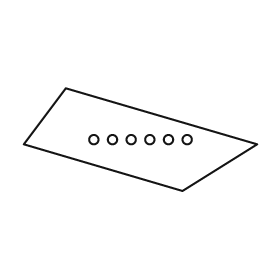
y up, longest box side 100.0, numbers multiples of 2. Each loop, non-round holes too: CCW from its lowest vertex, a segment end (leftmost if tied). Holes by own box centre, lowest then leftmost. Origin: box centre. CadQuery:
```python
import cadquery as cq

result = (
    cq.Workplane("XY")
    .moveTo(18.0, -22.0)
    .lineTo(50.0, -2.0)
    .lineTo(-32.0, 22.0)
    .lineTo(-50.0, -2.0)
    .close()
    .moveTo(-20.0, 0.0)
    .circle(2.0)
    .moveTo(-12.0, 0.0)
    .circle(2.0)
    .moveTo(-4.0, 0.0)
    .circle(2.0)
    .moveTo(4.0, 0.0)
    .circle(2.0)
    .moveTo(12.0, 0.0)
    .circle(2.0)
    .moveTo(20.0, 0.0)
    .circle(2.0)
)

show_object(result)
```